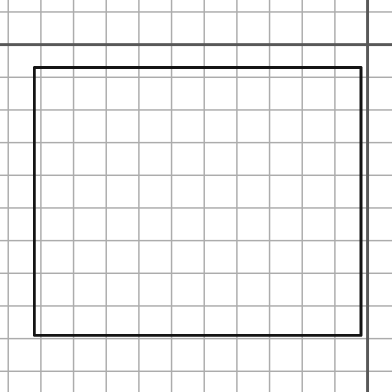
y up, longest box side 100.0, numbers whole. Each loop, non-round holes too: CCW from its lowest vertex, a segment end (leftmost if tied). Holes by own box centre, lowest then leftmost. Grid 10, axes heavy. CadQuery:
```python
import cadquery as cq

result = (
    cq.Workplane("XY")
    .moveTo(-102.0, -89.0)
    .lineTo(-2.0, -89.0)
    .lineTo(-2.0, -7.0)
    .lineTo(-102.0, -7.0)
    .close()
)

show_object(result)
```